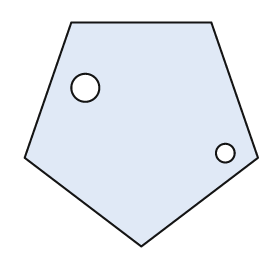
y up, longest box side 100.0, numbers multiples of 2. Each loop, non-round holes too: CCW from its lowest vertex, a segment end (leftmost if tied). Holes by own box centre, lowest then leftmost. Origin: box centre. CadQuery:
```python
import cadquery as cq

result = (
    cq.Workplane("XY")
    .moveTo(0.0, -48.0)
    .lineTo(50.0, -10.0)
    .lineTo(30.0, 48.0)
    .lineTo(-30.0, 48.0)
    .lineTo(-50.0, -10.0)
    .close()
    .moveTo(36.0, -8.0)
    .circle(4.0)
    .moveTo(-24.0, 20.0)
    .circle(6.0)
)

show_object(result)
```